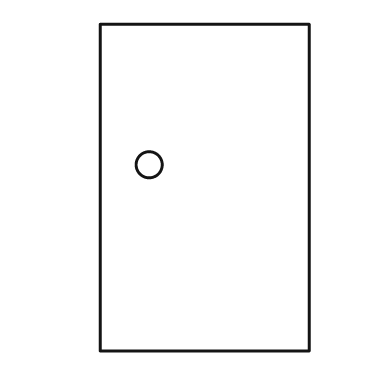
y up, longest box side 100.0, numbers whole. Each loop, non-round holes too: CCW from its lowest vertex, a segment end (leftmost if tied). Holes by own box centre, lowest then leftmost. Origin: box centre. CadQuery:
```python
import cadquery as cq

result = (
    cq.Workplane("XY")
    .moveTo(-32.0, -50.0)
    .lineTo(32.0, -50.0)
    .lineTo(32.0, 50.0)
    .lineTo(-32.0, 50.0)
    .close()
    .moveTo(-17.0, 7.0)
    .circle(4.0)
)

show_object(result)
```